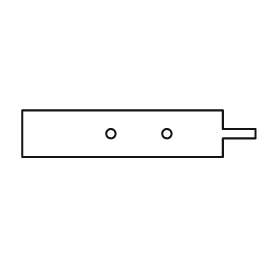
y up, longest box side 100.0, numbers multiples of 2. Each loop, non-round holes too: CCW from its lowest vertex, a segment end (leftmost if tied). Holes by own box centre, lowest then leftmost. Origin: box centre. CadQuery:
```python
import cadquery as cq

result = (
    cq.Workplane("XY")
    .moveTo(-50.0, -10.0)
    .lineTo(36.0, -10.0)
    .lineTo(36.0, -2.0)
    .lineTo(50.0, -2.0)
    .lineTo(50.0, 2.0)
    .lineTo(36.0, 2.0)
    .lineTo(36.0, 10.0)
    .lineTo(-50.0, 10.0)
    .close()
    .moveTo(-12.0, 0.0)
    .circle(2.0)
    .moveTo(12.0, 0.0)
    .circle(2.0)
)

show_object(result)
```